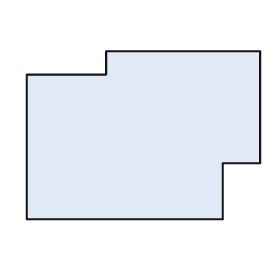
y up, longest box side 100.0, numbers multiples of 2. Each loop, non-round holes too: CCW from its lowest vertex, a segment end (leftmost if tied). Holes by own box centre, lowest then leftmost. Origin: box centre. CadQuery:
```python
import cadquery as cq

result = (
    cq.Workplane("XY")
    .moveTo(-50.0, -36.0)
    .lineTo(34.0, -36.0)
    .lineTo(34.0, -12.0)
    .lineTo(50.0, -12.0)
    .lineTo(50.0, 36.0)
    .lineTo(-16.0, 36.0)
    .lineTo(-16.0, 26.0)
    .lineTo(-50.0, 26.0)
    .close()
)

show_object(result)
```